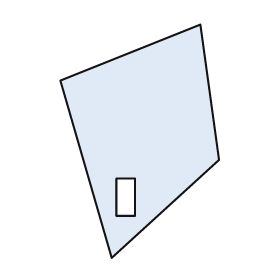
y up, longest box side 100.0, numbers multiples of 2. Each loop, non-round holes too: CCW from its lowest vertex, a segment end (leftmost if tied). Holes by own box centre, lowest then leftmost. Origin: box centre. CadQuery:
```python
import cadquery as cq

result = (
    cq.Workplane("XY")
    .moveTo(-12.0, -50.0)
    .lineTo(34.0, -8.0)
    .lineTo(26.0, 50.0)
    .lineTo(-34.0, 26.0)
    .close()
    .moveTo(-10.0, -32.0)
    .lineTo(-2.0, -32.0)
    .lineTo(-2.0, -16.0)
    .lineTo(-10.0, -16.0)
    .close()
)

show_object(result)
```